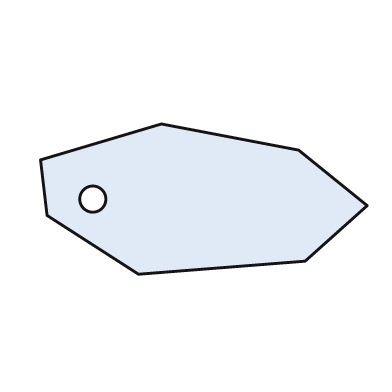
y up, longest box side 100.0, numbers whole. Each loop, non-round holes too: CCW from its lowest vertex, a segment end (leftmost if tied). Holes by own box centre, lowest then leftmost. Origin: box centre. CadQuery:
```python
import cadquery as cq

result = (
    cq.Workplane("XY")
    .moveTo(-20.0, -23.0)
    .lineTo(31.0, -19.0)
    .lineTo(50.0, -2.0)
    .lineTo(29.0, 15.0)
    .lineTo(-13.0, 23.0)
    .lineTo(-50.0, 12.0)
    .lineTo(-48.0, -5.0)
    .close()
    .moveTo(-34.0, 0.0)
    .circle(4.0)
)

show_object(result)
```